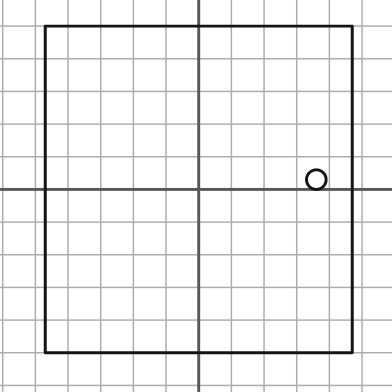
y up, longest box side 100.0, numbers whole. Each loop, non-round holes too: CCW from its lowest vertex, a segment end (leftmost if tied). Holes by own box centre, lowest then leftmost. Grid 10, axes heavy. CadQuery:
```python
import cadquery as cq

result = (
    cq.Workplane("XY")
    .moveTo(-47.0, -50.0)
    .lineTo(47.0, -50.0)
    .lineTo(47.0, 50.0)
    .lineTo(-47.0, 50.0)
    .close()
    .moveTo(36.0, 3.0)
    .circle(3.0)
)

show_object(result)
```